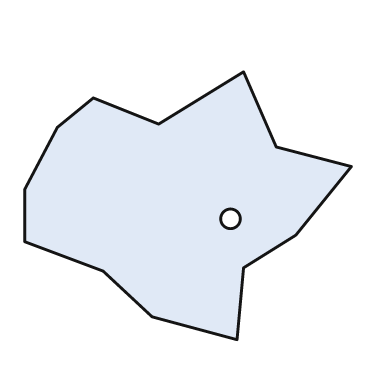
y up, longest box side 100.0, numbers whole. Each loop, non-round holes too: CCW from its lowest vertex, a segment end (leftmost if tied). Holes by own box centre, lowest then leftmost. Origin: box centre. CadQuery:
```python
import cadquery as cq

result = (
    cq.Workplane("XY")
    .moveTo(15.0, -41.0)
    .lineTo(17.0, -19.0)
    .lineTo(33.0, -9.0)
    .lineTo(50.0, 12.0)
    .lineTo(27.0, 18.0)
    .lineTo(17.0, 41.0)
    .lineTo(-9.0, 25.0)
    .lineTo(-29.0, 33.0)
    .lineTo(-40.0, 24.0)
    .lineTo(-50.0, 5.0)
    .lineTo(-50.0, -11.0)
    .lineTo(-26.0, -20.0)
    .lineTo(-11.0, -34.0)
    .close()
    .moveTo(13.0, -4.0)
    .circle(3.0)
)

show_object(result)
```